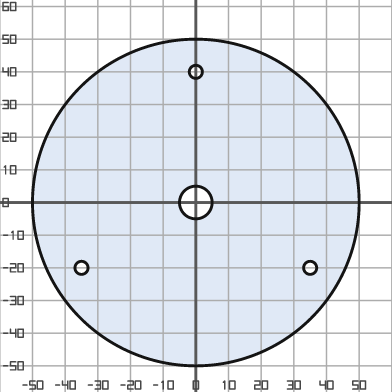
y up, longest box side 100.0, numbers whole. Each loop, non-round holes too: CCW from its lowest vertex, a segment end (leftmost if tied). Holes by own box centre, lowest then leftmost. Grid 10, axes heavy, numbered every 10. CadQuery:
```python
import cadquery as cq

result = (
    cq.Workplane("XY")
    .moveTo(0.0, 0.0)
    .circle(50.0)
    .moveTo(-35.0, -20.0)
    .circle(2.0)
    .moveTo(35.0, -20.0)
    .circle(2.0)
    .moveTo(0.0, 0.0)
    .circle(5.0)
    .moveTo(0.0, 40.0)
    .circle(2.0)
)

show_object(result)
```